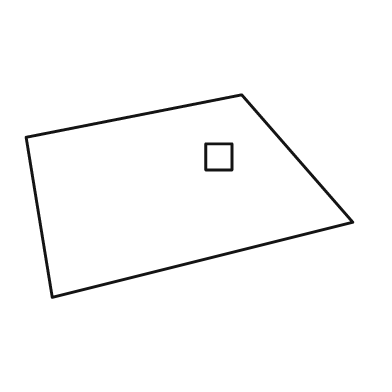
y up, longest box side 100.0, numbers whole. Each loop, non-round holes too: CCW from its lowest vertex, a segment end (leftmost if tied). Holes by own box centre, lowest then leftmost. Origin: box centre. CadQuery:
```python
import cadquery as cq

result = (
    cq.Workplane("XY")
    .moveTo(-42.0, -31.0)
    .lineTo(50.0, -8.0)
    .lineTo(16.0, 31.0)
    .lineTo(-50.0, 18.0)
    .close()
    .moveTo(5.0, 8.0)
    .lineTo(13.0, 8.0)
    .lineTo(13.0, 16.0)
    .lineTo(5.0, 16.0)
    .close()
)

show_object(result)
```